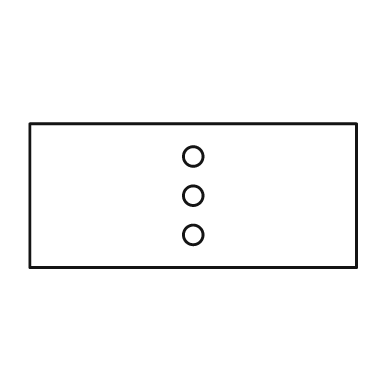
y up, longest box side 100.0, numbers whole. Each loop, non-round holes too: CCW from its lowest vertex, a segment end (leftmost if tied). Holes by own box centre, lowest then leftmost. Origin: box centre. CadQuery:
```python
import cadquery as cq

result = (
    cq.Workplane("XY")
    .moveTo(-50.0, -22.0)
    .lineTo(50.0, -22.0)
    .lineTo(50.0, 22.0)
    .lineTo(-50.0, 22.0)
    .close()
    .moveTo(0.0, -12.0)
    .circle(3.0)
    .moveTo(0.0, 0.0)
    .circle(3.0)
    .moveTo(0.0, 12.0)
    .circle(3.0)
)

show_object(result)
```